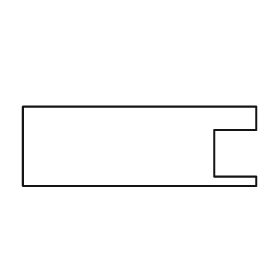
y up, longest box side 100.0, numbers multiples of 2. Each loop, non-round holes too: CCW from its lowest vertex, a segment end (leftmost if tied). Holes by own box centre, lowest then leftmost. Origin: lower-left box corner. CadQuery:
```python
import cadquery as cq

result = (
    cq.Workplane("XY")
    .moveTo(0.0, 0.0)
    .lineTo(100.0, 0.0)
    .lineTo(100.0, 4.0)
    .lineTo(82.0, 4.0)
    .lineTo(82.0, 24.0)
    .lineTo(100.0, 24.0)
    .lineTo(100.0, 34.0)
    .lineTo(0.0, 34.0)
    .close()
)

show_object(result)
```